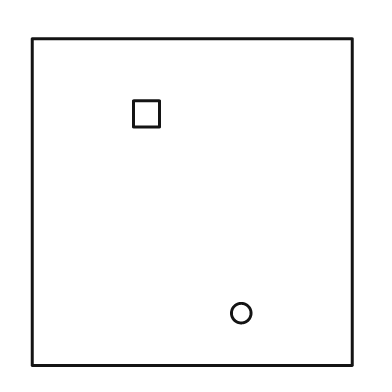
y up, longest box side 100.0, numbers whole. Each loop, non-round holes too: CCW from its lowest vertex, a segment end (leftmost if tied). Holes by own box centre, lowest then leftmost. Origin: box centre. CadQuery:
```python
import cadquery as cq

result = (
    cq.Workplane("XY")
    .moveTo(-49.0, -50.0)
    .lineTo(49.0, -50.0)
    .lineTo(49.0, 50.0)
    .lineTo(-49.0, 50.0)
    .close()
    .moveTo(15.0, -34.0)
    .circle(3.0)
    .moveTo(-18.0, 23.0)
    .lineTo(-10.0, 23.0)
    .lineTo(-10.0, 31.0)
    .lineTo(-18.0, 31.0)
    .close()
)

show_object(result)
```